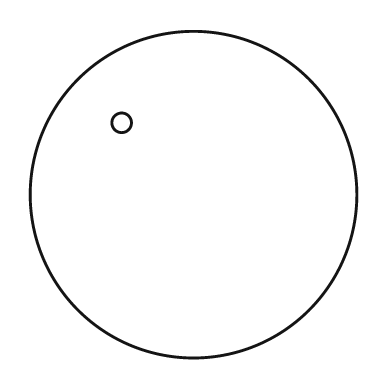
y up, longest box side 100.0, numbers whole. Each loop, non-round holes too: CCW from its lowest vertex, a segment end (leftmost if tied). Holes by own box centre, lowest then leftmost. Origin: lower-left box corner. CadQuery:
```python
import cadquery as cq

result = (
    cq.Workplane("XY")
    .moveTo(50.0, 50.0)
    .circle(50.0)
    .moveTo(28.0, 72.0)
    .circle(3.0)
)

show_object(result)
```